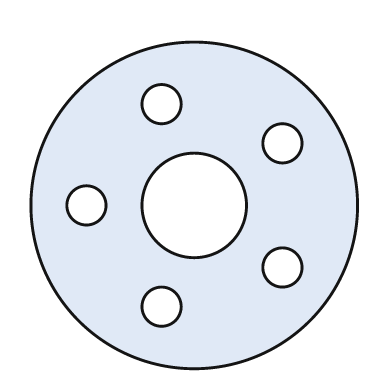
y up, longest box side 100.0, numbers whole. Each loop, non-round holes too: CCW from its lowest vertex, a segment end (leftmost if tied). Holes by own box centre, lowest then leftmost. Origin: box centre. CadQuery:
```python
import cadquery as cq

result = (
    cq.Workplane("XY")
    .moveTo(0.0, 0.0)
    .circle(50.0)
    .moveTo(-10.0, -31.0)
    .circle(6.0)
    .moveTo(27.0, -19.0)
    .circle(6.0)
    .moveTo(-33.0, 0.0)
    .circle(6.0)
    .moveTo(0.0, 0.0)
    .circle(16.0)
    .moveTo(27.0, 19.0)
    .circle(6.0)
    .moveTo(-10.0, 31.0)
    .circle(6.0)
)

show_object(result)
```